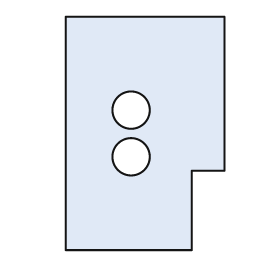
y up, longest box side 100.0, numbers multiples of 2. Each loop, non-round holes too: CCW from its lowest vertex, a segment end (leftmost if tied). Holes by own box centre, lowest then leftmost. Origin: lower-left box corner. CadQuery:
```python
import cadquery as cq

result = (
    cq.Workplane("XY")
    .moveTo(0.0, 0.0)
    .lineTo(54.0, 0.0)
    .lineTo(54.0, 34.0)
    .lineTo(68.0, 34.0)
    .lineTo(68.0, 100.0)
    .lineTo(0.0, 100.0)
    .close()
    .moveTo(28.0, 40.0)
    .circle(8.0)
    .moveTo(28.0, 60.0)
    .circle(8.0)
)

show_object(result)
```